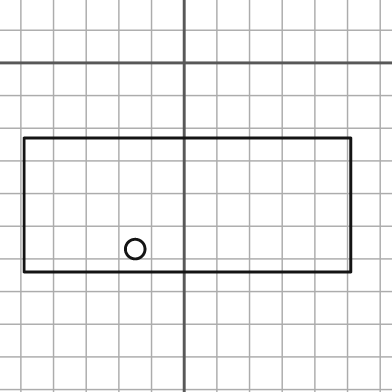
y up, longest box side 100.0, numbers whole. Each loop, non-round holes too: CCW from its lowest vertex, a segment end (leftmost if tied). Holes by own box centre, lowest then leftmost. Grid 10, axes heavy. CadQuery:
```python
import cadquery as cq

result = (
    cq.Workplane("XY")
    .moveTo(-49.0, -64.0)
    .lineTo(51.0, -64.0)
    .lineTo(51.0, -23.0)
    .lineTo(-49.0, -23.0)
    .close()
    .moveTo(-15.0, -57.0)
    .circle(3.0)
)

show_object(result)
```